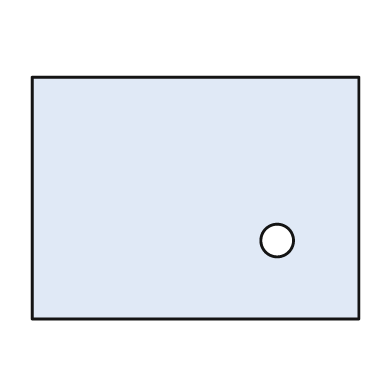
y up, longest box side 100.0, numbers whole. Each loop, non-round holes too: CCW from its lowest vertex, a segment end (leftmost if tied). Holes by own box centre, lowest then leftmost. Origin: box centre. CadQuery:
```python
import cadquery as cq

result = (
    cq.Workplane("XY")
    .moveTo(-50.0, -37.0)
    .lineTo(50.0, -37.0)
    .lineTo(50.0, 37.0)
    .lineTo(-50.0, 37.0)
    .close()
    .moveTo(25.0, -13.0)
    .circle(5.0)
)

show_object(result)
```